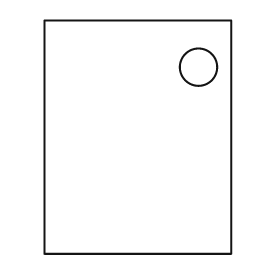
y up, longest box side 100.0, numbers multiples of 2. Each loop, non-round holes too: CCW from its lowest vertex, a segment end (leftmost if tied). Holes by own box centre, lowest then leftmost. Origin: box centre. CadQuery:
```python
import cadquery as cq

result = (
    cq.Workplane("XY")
    .moveTo(-40.0, -50.0)
    .lineTo(40.0, -50.0)
    .lineTo(40.0, 50.0)
    .lineTo(-40.0, 50.0)
    .close()
    .moveTo(26.0, 30.0)
    .circle(8.0)
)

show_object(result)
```